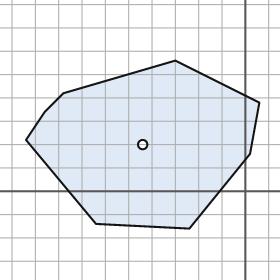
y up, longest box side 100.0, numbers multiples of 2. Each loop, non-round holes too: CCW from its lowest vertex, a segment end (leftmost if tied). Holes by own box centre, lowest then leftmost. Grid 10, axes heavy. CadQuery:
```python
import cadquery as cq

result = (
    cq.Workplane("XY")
    .moveTo(-24.0, -16.0)
    .lineTo(2.0, 16.0)
    .lineTo(6.0, 38.0)
    .lineTo(-30.0, 56.0)
    .lineTo(-78.0, 42.0)
    .lineTo(-86.0, 34.0)
    .lineTo(-94.0, 22.0)
    .lineTo(-64.0, -14.0)
    .close()
    .moveTo(-44.0, 20.0)
    .circle(2.0)
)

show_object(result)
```